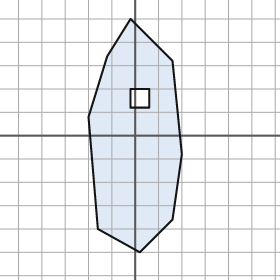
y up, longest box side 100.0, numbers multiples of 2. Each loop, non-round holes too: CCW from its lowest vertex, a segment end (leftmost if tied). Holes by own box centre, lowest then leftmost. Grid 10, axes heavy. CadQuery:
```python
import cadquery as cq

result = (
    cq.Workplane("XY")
    .moveTo(2.0, -50.0)
    .lineTo(16.0, -36.0)
    .lineTo(20.0, -8.0)
    .lineTo(16.0, 32.0)
    .lineTo(-2.0, 50.0)
    .lineTo(-12.0, 34.0)
    .lineTo(-20.0, 8.0)
    .lineTo(-16.0, -40.0)
    .close()
    .moveTo(-2.0, 12.0)
    .lineTo(6.0, 12.0)
    .lineTo(6.0, 20.0)
    .lineTo(-2.0, 20.0)
    .close()
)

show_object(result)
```